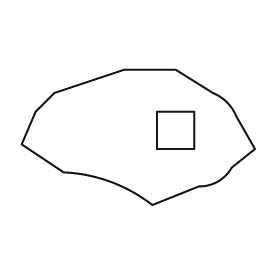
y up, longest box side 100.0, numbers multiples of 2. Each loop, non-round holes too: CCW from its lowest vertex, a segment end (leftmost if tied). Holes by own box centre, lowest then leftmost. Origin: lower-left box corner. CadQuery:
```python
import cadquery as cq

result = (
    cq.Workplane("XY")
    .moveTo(56.0, 0.0)
    .lineTo(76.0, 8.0)
    .threePointArc((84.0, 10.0), (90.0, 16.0))
    .lineTo(100.0, 24.0)
    .lineTo(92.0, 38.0)
    .threePointArc((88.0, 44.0), (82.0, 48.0))
    .lineTo(66.0, 58.0)
    .lineTo(44.0, 58.0)
    .lineTo(14.0, 48.0)
    .lineTo(6.0, 40.0)
    .lineTo(0.0, 26.0)
    .lineTo(18.0, 14.0)
    .threePointArc((38.0, 10.0), (56.0, 0.0))
    .close()
    .moveTo(58.0, 24.0)
    .lineTo(74.0, 24.0)
    .lineTo(74.0, 40.0)
    .lineTo(58.0, 40.0)
    .close()
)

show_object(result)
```